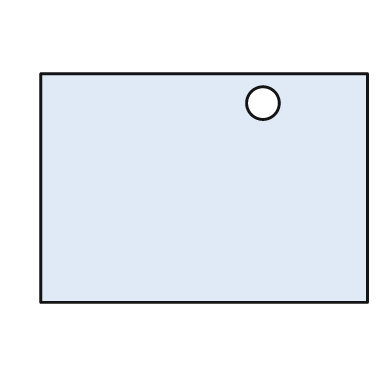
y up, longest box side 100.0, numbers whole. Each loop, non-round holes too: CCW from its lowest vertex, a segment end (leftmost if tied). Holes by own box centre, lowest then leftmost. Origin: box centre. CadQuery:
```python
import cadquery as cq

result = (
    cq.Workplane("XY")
    .moveTo(-50.0, -35.0)
    .lineTo(50.0, -35.0)
    .lineTo(50.0, 35.0)
    .lineTo(-50.0, 35.0)
    .close()
    .moveTo(18.0, 26.0)
    .circle(5.0)
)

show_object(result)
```